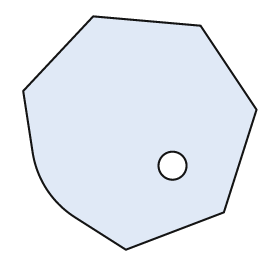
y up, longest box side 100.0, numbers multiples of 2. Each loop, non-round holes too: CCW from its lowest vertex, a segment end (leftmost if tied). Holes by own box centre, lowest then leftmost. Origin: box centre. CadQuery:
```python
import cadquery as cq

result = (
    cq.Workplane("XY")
    .moveTo(-6.0, -50.0)
    .lineTo(36.0, -34.0)
    .lineTo(50.0, 10.0)
    .lineTo(26.0, 46.0)
    .lineTo(-20.0, 50.0)
    .lineTo(-50.0, 18.0)
    .lineTo(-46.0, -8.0)
    .threePointArc((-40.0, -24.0), (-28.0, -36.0))
    .close()
    .moveTo(14.0, -14.0)
    .circle(6.0)
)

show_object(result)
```